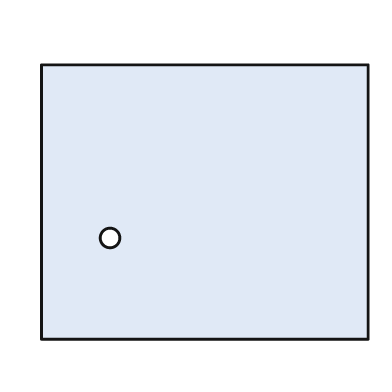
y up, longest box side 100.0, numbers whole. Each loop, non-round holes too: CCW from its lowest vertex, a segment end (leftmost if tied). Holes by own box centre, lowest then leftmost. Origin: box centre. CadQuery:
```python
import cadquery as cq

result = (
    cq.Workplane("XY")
    .moveTo(-50.0, -42.0)
    .lineTo(50.0, -42.0)
    .lineTo(50.0, 42.0)
    .lineTo(-50.0, 42.0)
    .close()
    .moveTo(-29.0, -11.0)
    .circle(3.0)
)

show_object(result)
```